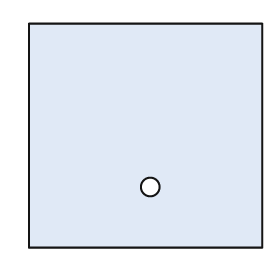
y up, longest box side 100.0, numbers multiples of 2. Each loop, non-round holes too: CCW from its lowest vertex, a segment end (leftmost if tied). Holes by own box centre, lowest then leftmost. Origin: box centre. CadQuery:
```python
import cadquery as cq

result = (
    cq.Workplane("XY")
    .moveTo(-50.0, -48.0)
    .lineTo(50.0, -48.0)
    .lineTo(50.0, 48.0)
    .lineTo(-50.0, 48.0)
    .close()
    .moveTo(2.0, -22.0)
    .circle(4.0)
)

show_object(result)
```